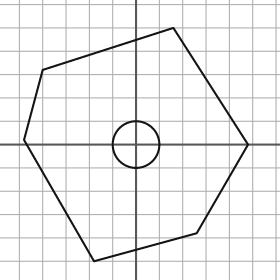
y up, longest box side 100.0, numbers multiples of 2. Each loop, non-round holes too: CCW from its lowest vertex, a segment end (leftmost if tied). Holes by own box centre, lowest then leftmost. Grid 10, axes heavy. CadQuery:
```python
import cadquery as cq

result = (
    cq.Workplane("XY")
    .moveTo(-18.0, -50.0)
    .lineTo(26.0, -38.0)
    .lineTo(48.0, 0.0)
    .lineTo(16.0, 50.0)
    .lineTo(-40.0, 32.0)
    .lineTo(-48.0, 2.0)
    .close()
    .moveTo(0.0, 0.0)
    .circle(10.0)
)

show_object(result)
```